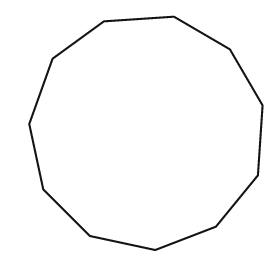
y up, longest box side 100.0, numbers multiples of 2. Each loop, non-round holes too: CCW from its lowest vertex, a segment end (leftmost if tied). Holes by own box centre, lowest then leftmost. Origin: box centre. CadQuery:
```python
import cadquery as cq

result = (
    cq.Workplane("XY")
    .moveTo(4.0, -50.0)
    .lineTo(30.0, -40.0)
    .lineTo(48.0, -18.0)
    .lineTo(50.0, 12.0)
    .lineTo(36.0, 36.0)
    .lineTo(12.0, 50.0)
    .lineTo(-18.0, 48.0)
    .lineTo(-40.0, 32.0)
    .lineTo(-50.0, 4.0)
    .lineTo(-44.0, -24.0)
    .lineTo(-24.0, -44.0)
    .close()
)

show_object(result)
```